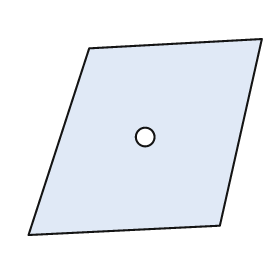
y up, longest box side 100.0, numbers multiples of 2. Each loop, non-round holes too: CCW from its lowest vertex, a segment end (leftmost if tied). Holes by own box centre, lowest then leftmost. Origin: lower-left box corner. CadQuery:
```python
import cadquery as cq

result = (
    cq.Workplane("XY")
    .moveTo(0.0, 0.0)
    .lineTo(82.0, 4.0)
    .lineTo(100.0, 84.0)
    .lineTo(26.0, 80.0)
    .close()
    .moveTo(50.0, 42.0)
    .circle(4.0)
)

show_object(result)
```